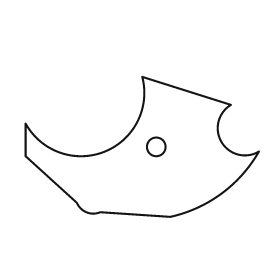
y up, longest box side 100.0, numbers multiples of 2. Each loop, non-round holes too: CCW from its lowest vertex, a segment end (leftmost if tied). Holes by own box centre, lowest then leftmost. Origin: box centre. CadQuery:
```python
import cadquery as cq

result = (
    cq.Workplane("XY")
    .moveTo(12.0, -30.0)
    .threePointArc((34.0, -20.0), (50.0, -2.0))
    .threePointArc((34.0, 2.0), (38.0, 18.0))
    .lineTo(0.0, 30.0)
    .threePointArc((-16.0, -2.0), (-50.0, 10.0))
    .lineTo(-50.0, -4.0)
    .lineTo(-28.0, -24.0)
    .threePointArc((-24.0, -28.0), (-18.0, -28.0))
    .close()
    .moveTo(6.0, 0.0)
    .circle(4.0)
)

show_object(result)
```